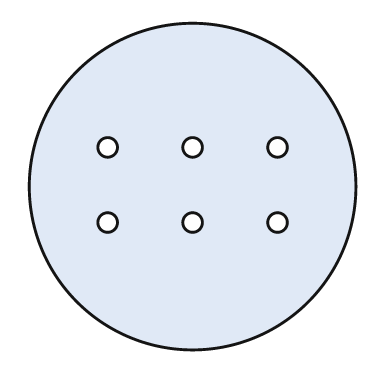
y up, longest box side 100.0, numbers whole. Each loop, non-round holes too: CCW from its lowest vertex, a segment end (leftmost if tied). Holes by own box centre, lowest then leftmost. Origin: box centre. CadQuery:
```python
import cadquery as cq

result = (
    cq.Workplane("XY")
    .moveTo(0.0, 0.0)
    .circle(50.0)
    .moveTo(-26.0, -11.0)
    .circle(3.0)
    .moveTo(0.0, -11.0)
    .circle(3.0)
    .moveTo(26.0, -11.0)
    .circle(3.0)
    .moveTo(-26.0, 12.0)
    .circle(3.0)
    .moveTo(0.0, 12.0)
    .circle(3.0)
    .moveTo(26.0, 12.0)
    .circle(3.0)
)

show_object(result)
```